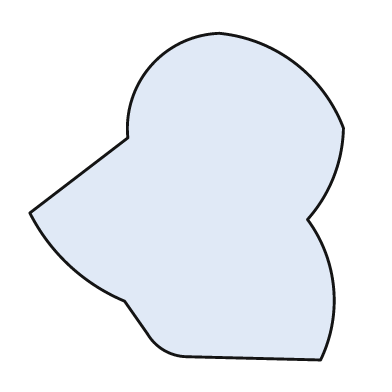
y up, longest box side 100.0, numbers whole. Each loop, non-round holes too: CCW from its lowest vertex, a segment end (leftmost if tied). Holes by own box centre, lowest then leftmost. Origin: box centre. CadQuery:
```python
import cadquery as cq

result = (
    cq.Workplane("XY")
    .moveTo(41.0, -50.0)
    .threePointArc((45.0, -28.0), (37.0, -7.0))
    .threePointArc((45.0, 6.0), (48.0, 21.0))
    .threePointArc((33.0, 41.0), (10.0, 50.0))
    .threePointArc((-11.0, 40.0), (-18.0, 18.0))
    .lineTo(-48.0, -5.0)
    .threePointArc((-36.0, -21.0), (-19.0, -32.0))
    .lineTo(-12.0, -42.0)
    .threePointArc((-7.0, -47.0), (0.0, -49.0))
    .close()
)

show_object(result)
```